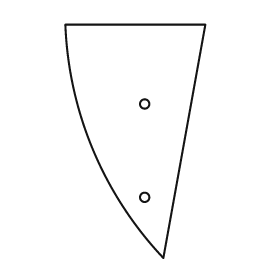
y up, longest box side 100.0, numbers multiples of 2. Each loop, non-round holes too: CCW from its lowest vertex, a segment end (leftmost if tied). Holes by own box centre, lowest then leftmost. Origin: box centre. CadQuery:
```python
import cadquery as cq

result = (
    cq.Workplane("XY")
    .moveTo(12.0, -50.0)
    .lineTo(30.0, 50.0)
    .lineTo(-30.0, 50.0)
    .threePointArc((-18.0, -4.0), (12.0, -50.0))
    .close()
    .moveTo(4.0, -24.0)
    .circle(2.0)
    .moveTo(4.0, 16.0)
    .circle(2.0)
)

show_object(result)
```